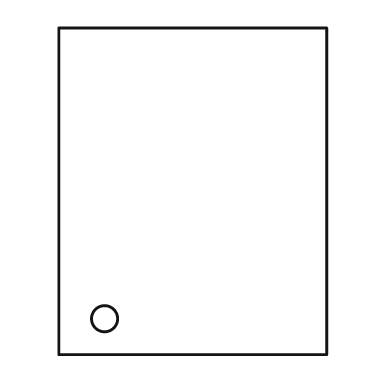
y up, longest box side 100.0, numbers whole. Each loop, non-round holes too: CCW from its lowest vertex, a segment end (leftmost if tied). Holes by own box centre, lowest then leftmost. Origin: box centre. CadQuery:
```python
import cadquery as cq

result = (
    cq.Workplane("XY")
    .moveTo(-41.0, -50.0)
    .lineTo(41.0, -50.0)
    .lineTo(41.0, 50.0)
    .lineTo(-41.0, 50.0)
    .close()
    .moveTo(-27.0, -39.0)
    .circle(4.0)
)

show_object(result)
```